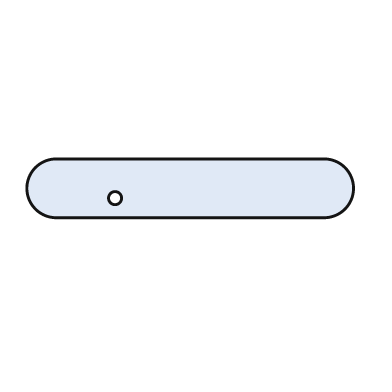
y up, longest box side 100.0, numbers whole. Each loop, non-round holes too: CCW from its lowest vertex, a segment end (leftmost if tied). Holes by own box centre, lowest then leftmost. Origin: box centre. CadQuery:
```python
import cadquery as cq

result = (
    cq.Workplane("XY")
    .moveTo(-41.0, -9.0)
    .lineTo(41.0, -9.0)
    .threePointArc((50.0, 0.0), (41.0, 9.0))
    .lineTo(-41.0, 9.0)
    .threePointArc((-50.0, 0.0), (-41.0, -9.0))
    .close()
    .moveTo(-23.0, -3.0)
    .circle(2.0)
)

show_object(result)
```